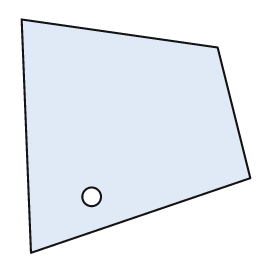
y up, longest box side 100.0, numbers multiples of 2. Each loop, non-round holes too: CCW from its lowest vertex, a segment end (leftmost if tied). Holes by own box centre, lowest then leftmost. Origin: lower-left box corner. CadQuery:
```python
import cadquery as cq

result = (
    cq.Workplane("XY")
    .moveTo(4.0, 0.0)
    .lineTo(98.0, 32.0)
    .lineTo(84.0, 88.0)
    .lineTo(0.0, 100.0)
    .close()
    .moveTo(30.0, 24.0)
    .circle(4.0)
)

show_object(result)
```